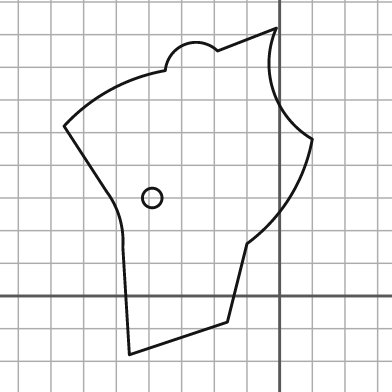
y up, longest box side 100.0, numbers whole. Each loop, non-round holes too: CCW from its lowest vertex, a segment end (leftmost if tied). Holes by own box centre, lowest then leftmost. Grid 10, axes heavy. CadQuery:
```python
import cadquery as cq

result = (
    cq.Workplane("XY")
    .moveTo(-46.0, -18.0)
    .lineTo(-16.0, -8.0)
    .lineTo(-10.0, 16.0)
    .threePointArc((3.0, 30.0), (10.0, 48.0))
    .threePointArc((-2.0, 63.0), (-1.0, 82.0))
    .lineTo(-19.0, 75.0)
    .threePointArc((-29.0, 77.0), (-35.0, 69.0))
    .threePointArc((-52.0, 63.0), (-66.0, 52.0))
    .lineTo(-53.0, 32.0)
    .threePointArc((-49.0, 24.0), (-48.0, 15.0))
    .close()
    .moveTo(-39.0, 30.0)
    .circle(3.0)
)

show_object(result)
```